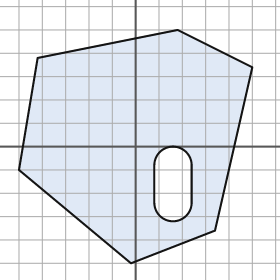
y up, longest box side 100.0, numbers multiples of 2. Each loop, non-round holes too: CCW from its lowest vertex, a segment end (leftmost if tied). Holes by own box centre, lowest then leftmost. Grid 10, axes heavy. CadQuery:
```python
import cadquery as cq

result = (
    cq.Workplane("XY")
    .moveTo(-2.0, -50.0)
    .lineTo(34.0, -36.0)
    .lineTo(50.0, 34.0)
    .lineTo(18.0, 50.0)
    .lineTo(-42.0, 38.0)
    .lineTo(-50.0, -10.0)
    .close()
    .moveTo(8.0, -24.0)
    .threePointArc((16.0, -32.0), (24.0, -24.0))
    .lineTo(24.0, -8.0)
    .threePointArc((16.0, 0.0), (8.0, -8.0))
    .close()
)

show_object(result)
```